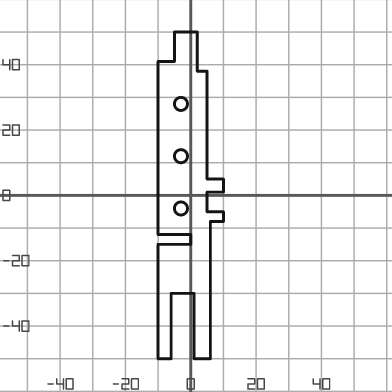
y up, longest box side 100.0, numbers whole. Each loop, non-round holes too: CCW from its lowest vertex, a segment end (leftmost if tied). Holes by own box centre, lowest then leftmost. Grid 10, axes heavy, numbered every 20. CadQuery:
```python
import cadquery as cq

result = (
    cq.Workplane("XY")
    .moveTo(-10.0, -50.0)
    .lineTo(-6.0, -50.0)
    .lineTo(-6.0, -30.0)
    .lineTo(1.0, -30.0)
    .lineTo(1.0, -50.0)
    .lineTo(6.0, -50.0)
    .lineTo(6.0, -8.0)
    .lineTo(10.0, -8.0)
    .lineTo(10.0, -5.0)
    .lineTo(5.0, -5.0)
    .lineTo(5.0, 1.0)
    .lineTo(10.0, 1.0)
    .lineTo(10.0, 5.0)
    .lineTo(5.0, 5.0)
    .lineTo(5.0, 38.0)
    .lineTo(2.0, 38.0)
    .lineTo(2.0, 50.0)
    .lineTo(-5.0, 50.0)
    .lineTo(-5.0, 41.0)
    .lineTo(-10.0, 41.0)
    .lineTo(-10.0, -12.0)
    .lineTo(0.0, -12.0)
    .lineTo(0.0, -15.0)
    .lineTo(-10.0, -15.0)
    .close()
    .moveTo(-3.0, -4.0)
    .circle(2.0)
    .moveTo(-3.0, 12.0)
    .circle(2.0)
    .moveTo(-3.0, 28.0)
    .circle(2.0)
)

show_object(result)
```